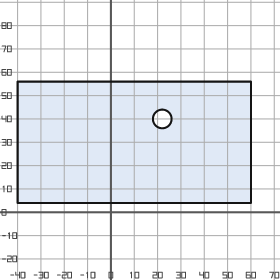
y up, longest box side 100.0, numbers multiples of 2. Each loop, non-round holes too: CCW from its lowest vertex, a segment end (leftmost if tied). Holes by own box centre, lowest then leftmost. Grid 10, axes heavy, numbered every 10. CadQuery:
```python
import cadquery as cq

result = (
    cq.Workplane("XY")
    .moveTo(-40.0, 4.0)
    .lineTo(60.0, 4.0)
    .lineTo(60.0, 56.0)
    .lineTo(-40.0, 56.0)
    .close()
    .moveTo(22.0, 40.0)
    .circle(4.0)
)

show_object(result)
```